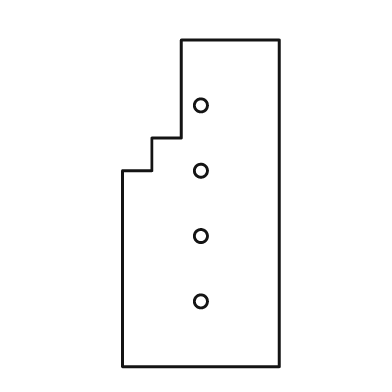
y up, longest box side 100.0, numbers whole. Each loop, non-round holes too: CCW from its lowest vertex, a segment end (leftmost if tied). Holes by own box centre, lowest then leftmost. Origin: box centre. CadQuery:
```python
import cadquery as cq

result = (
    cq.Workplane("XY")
    .moveTo(-24.0, -50.0)
    .lineTo(24.0, -50.0)
    .lineTo(24.0, 50.0)
    .lineTo(-6.0, 50.0)
    .lineTo(-6.0, 20.0)
    .lineTo(-15.0, 20.0)
    .lineTo(-15.0, 10.0)
    .lineTo(-24.0, 10.0)
    .close()
    .moveTo(0.0, -30.0)
    .circle(2.0)
    .moveTo(0.0, -10.0)
    .circle(2.0)
    .moveTo(0.0, 10.0)
    .circle(2.0)
    .moveTo(0.0, 30.0)
    .circle(2.0)
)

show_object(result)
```